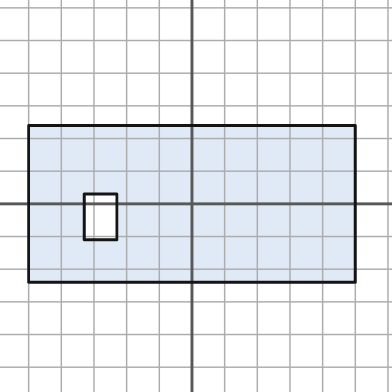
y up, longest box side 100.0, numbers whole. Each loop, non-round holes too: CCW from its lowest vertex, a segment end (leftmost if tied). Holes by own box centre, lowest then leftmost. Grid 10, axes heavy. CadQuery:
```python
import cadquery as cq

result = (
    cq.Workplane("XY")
    .moveTo(-50.0, -24.0)
    .lineTo(50.0, -24.0)
    .lineTo(50.0, 24.0)
    .lineTo(-50.0, 24.0)
    .close()
    .moveTo(-33.0, -11.0)
    .lineTo(-23.0, -11.0)
    .lineTo(-23.0, 3.0)
    .lineTo(-33.0, 3.0)
    .close()
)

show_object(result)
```